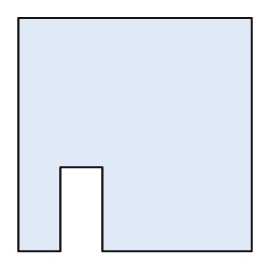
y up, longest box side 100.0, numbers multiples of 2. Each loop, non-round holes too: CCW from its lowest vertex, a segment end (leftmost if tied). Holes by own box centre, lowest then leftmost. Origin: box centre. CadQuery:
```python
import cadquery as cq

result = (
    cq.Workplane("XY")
    .moveTo(-50.0, -50.0)
    .lineTo(-32.0, -50.0)
    .lineTo(-32.0, -14.0)
    .lineTo(-14.0, -14.0)
    .lineTo(-14.0, -50.0)
    .lineTo(50.0, -50.0)
    .lineTo(50.0, 50.0)
    .lineTo(-50.0, 50.0)
    .close()
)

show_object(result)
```